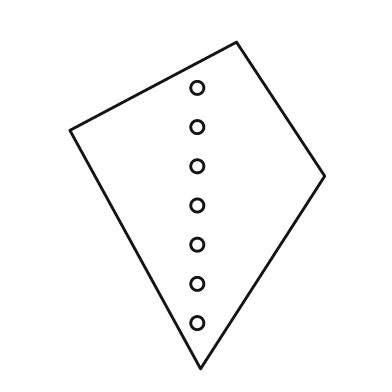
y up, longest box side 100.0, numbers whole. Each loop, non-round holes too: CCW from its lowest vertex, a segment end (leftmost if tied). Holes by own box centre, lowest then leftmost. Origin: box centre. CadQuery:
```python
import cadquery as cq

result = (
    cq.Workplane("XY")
    .moveTo(1.0, -50.0)
    .lineTo(39.0, 9.0)
    .lineTo(12.0, 50.0)
    .lineTo(-39.0, 23.0)
    .close()
    .moveTo(0.0, -36.0)
    .circle(2.0)
    .moveTo(0.0, -24.0)
    .circle(2.0)
    .moveTo(0.0, -12.0)
    .circle(2.0)
    .moveTo(0.0, 0.0)
    .circle(2.0)
    .moveTo(0.0, 12.0)
    .circle(2.0)
    .moveTo(0.0, 24.0)
    .circle(2.0)
    .moveTo(0.0, 36.0)
    .circle(2.0)
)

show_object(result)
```